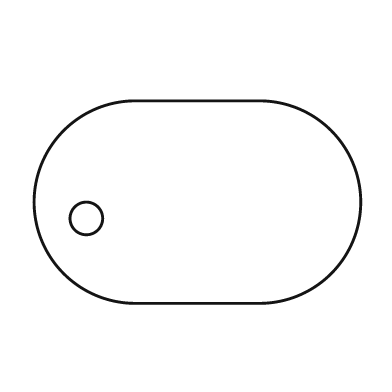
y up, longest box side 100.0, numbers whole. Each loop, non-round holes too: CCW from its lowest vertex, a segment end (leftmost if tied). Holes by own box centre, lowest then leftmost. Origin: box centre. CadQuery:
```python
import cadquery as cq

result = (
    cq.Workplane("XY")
    .moveTo(-19.0, -31.0)
    .lineTo(19.0, -31.0)
    .threePointArc((50.0, 0.0), (19.0, 31.0))
    .lineTo(-19.0, 31.0)
    .threePointArc((-50.0, 0.0), (-19.0, -31.0))
    .close()
    .moveTo(-34.0, -5.0)
    .circle(5.0)
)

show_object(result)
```